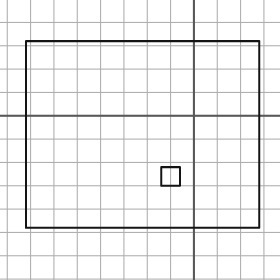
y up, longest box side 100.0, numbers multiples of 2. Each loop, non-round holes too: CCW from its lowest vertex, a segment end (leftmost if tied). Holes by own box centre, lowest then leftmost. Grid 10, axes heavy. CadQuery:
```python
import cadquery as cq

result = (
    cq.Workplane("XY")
    .moveTo(-72.0, -48.0)
    .lineTo(28.0, -48.0)
    .lineTo(28.0, 32.0)
    .lineTo(-72.0, 32.0)
    .close()
    .moveTo(-14.0, -30.0)
    .lineTo(-6.0, -30.0)
    .lineTo(-6.0, -22.0)
    .lineTo(-14.0, -22.0)
    .close()
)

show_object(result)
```